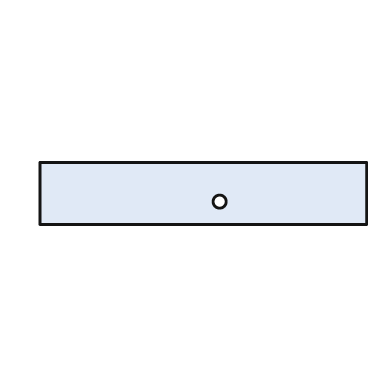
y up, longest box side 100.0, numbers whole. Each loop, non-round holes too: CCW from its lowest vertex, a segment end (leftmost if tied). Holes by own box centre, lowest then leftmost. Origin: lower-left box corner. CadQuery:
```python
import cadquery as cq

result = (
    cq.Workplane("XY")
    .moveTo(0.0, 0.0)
    .lineTo(100.0, 0.0)
    .lineTo(100.0, 19.0)
    .lineTo(0.0, 19.0)
    .close()
    .moveTo(55.0, 7.0)
    .circle(2.0)
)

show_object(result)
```